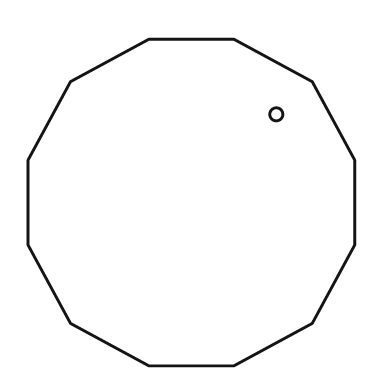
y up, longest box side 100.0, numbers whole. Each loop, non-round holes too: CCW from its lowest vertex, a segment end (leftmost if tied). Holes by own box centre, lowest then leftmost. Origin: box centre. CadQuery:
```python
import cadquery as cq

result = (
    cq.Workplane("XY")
    .moveTo(-13.0, -50.0)
    .lineTo(13.0, -50.0)
    .lineTo(37.0, -37.0)
    .lineTo(50.0, -13.0)
    .lineTo(50.0, 13.0)
    .lineTo(37.0, 37.0)
    .lineTo(13.0, 50.0)
    .lineTo(-13.0, 50.0)
    .lineTo(-37.0, 37.0)
    .lineTo(-50.0, 13.0)
    .lineTo(-50.0, -13.0)
    .lineTo(-37.0, -37.0)
    .close()
    .moveTo(26.0, 27.0)
    .circle(2.0)
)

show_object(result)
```